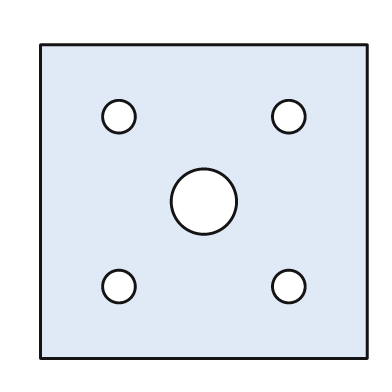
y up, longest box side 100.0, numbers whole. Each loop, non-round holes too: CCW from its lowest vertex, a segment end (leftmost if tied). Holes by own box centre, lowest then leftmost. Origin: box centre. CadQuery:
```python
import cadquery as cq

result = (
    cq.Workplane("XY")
    .moveTo(-50.0, -48.0)
    .lineTo(50.0, -48.0)
    .lineTo(50.0, 48.0)
    .lineTo(-50.0, 48.0)
    .close()
    .moveTo(-26.0, -26.0)
    .circle(5.0)
    .moveTo(26.0, -26.0)
    .circle(5.0)
    .moveTo(0.0, 0.0)
    .circle(10.0)
    .moveTo(-26.0, 26.0)
    .circle(5.0)
    .moveTo(26.0, 26.0)
    .circle(5.0)
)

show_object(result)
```